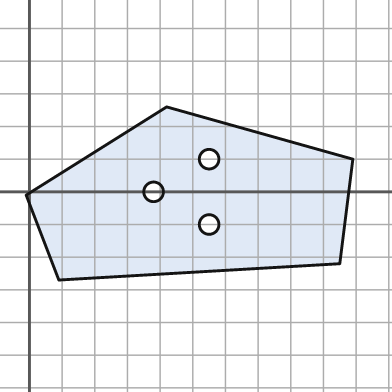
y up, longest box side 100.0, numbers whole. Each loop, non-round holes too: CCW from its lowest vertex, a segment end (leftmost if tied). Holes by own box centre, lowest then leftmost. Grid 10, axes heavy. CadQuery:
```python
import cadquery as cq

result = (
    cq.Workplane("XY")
    .moveTo(9.0, -27.0)
    .lineTo(95.0, -22.0)
    .lineTo(99.0, 10.0)
    .lineTo(42.0, 26.0)
    .lineTo(-1.0, -1.0)
    .close()
    .moveTo(55.0, -10.0)
    .circle(3.0)
    .moveTo(38.0, 0.0)
    .circle(3.0)
    .moveTo(55.0, 10.0)
    .circle(3.0)
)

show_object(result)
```